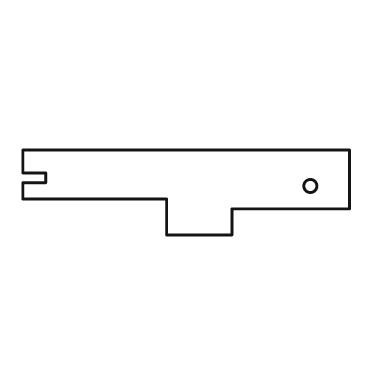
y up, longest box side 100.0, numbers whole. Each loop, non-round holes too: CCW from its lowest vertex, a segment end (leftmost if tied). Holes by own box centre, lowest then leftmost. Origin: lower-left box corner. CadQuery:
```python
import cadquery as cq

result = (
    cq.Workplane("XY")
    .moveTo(44.0, 0.0)
    .lineTo(64.0, 0.0)
    .lineTo(64.0, 8.0)
    .lineTo(100.0, 8.0)
    .lineTo(100.0, 26.0)
    .lineTo(0.0, 26.0)
    .lineTo(0.0, 19.0)
    .lineTo(7.0, 19.0)
    .lineTo(7.0, 16.0)
    .lineTo(0.0, 16.0)
    .lineTo(0.0, 11.0)
    .lineTo(44.0, 11.0)
    .close()
    .moveTo(88.0, 15.0)
    .circle(2.0)
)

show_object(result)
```